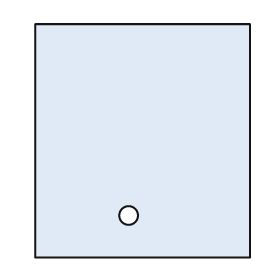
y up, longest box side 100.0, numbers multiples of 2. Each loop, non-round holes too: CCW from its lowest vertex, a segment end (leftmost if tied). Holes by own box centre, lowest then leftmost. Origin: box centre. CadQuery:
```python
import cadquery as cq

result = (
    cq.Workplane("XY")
    .moveTo(-46.0, -50.0)
    .lineTo(46.0, -50.0)
    .lineTo(46.0, 50.0)
    .lineTo(-46.0, 50.0)
    .close()
    .moveTo(-6.0, -32.0)
    .circle(4.0)
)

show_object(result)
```